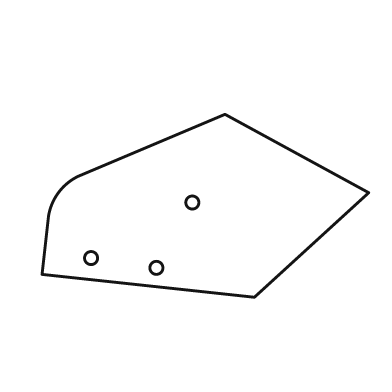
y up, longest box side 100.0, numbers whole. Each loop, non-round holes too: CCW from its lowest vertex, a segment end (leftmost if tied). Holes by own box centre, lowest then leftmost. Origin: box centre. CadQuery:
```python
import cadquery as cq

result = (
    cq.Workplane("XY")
    .moveTo(15.0, -28.0)
    .lineTo(50.0, 4.0)
    .lineTo(6.0, 28.0)
    .lineTo(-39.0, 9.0)
    .threePointArc((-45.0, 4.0), (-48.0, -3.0))
    .lineTo(-50.0, -21.0)
    .close()
    .moveTo(-15.0, -19.0)
    .circle(2.0)
    .moveTo(-35.0, -16.0)
    .circle(2.0)
    .moveTo(-4.0, 1.0)
    .circle(2.0)
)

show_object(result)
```